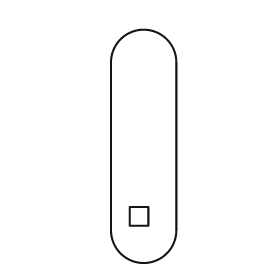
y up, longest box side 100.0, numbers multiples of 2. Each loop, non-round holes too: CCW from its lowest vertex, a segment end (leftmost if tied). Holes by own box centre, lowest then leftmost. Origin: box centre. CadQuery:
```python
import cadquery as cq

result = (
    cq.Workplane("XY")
    .moveTo(-14.0, -36.0)
    .threePointArc((0.0, -50.0), (14.0, -36.0))
    .lineTo(14.0, 36.0)
    .threePointArc((0.0, 50.0), (-14.0, 36.0))
    .close()
    .moveTo(-6.0, -34.0)
    .lineTo(2.0, -34.0)
    .lineTo(2.0, -26.0)
    .lineTo(-6.0, -26.0)
    .close()
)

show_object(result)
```